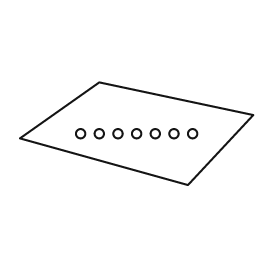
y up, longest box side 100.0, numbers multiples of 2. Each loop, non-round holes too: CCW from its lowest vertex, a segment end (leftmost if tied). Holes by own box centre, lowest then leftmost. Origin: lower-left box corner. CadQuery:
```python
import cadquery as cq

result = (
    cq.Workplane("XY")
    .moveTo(72.0, 0.0)
    .lineTo(100.0, 30.0)
    .lineTo(34.0, 44.0)
    .lineTo(0.0, 20.0)
    .close()
    .moveTo(26.0, 22.0)
    .circle(2.0)
    .moveTo(34.0, 22.0)
    .circle(2.0)
    .moveTo(42.0, 22.0)
    .circle(2.0)
    .moveTo(50.0, 22.0)
    .circle(2.0)
    .moveTo(58.0, 22.0)
    .circle(2.0)
    .moveTo(66.0, 22.0)
    .circle(2.0)
    .moveTo(74.0, 22.0)
    .circle(2.0)
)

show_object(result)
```